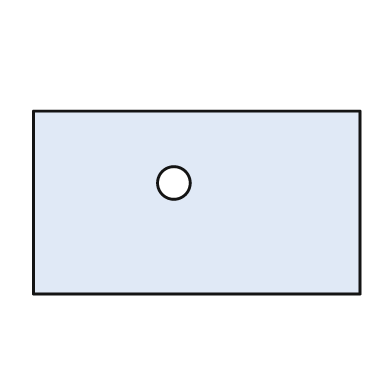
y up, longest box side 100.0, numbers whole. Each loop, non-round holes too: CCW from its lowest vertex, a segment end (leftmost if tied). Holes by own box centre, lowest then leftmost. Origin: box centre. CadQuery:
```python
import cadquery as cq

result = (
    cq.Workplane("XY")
    .moveTo(-50.0, -28.0)
    .lineTo(50.0, -28.0)
    .lineTo(50.0, 28.0)
    .lineTo(-50.0, 28.0)
    .close()
    .moveTo(-7.0, 6.0)
    .circle(5.0)
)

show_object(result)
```